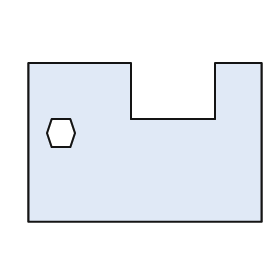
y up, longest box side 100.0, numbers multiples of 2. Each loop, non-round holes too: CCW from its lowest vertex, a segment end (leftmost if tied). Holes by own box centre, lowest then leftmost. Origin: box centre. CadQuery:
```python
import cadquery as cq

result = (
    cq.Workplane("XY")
    .moveTo(-50.0, -34.0)
    .lineTo(50.0, -34.0)
    .lineTo(50.0, 34.0)
    .lineTo(30.0, 34.0)
    .lineTo(30.0, 10.0)
    .lineTo(-6.0, 10.0)
    .lineTo(-6.0, 34.0)
    .lineTo(-50.0, 34.0)
    .close()
    .moveTo(-40.0, -2.0)
    .lineTo(-32.0, -2.0)
    .lineTo(-30.0, 4.0)
    .lineTo(-32.0, 10.0)
    .lineTo(-40.0, 10.0)
    .lineTo(-42.0, 4.0)
    .close()
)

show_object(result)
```